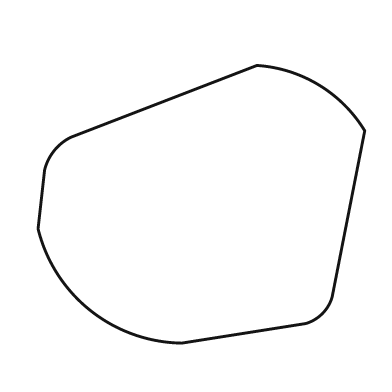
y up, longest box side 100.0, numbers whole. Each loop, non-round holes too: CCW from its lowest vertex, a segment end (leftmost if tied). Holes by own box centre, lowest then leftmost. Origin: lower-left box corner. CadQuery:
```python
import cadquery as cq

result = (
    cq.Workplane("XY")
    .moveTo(44.0, 0.0)
    .lineTo(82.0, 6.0)
    .threePointArc((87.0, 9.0), (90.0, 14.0))
    .lineTo(100.0, 65.0)
    .threePointArc((86.0, 79.0), (67.0, 85.0))
    .lineTo(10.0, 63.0)
    .threePointArc((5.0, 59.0), (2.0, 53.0))
    .lineTo(0.0, 35.0)
    .threePointArc((16.0, 10.0), (44.0, 0.0))
    .close()
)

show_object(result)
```